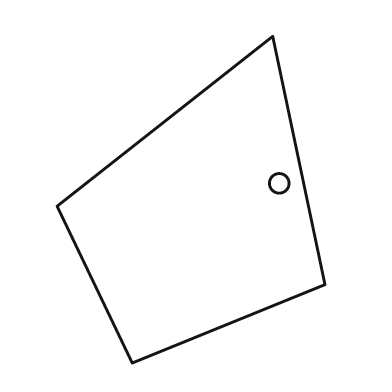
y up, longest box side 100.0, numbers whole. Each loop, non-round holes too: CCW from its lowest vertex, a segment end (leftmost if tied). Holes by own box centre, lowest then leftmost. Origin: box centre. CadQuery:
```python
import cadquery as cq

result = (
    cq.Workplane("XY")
    .moveTo(-18.0, -50.0)
    .lineTo(41.0, -26.0)
    .lineTo(25.0, 50.0)
    .lineTo(-41.0, -2.0)
    .close()
    .moveTo(27.0, 5.0)
    .circle(3.0)
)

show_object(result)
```